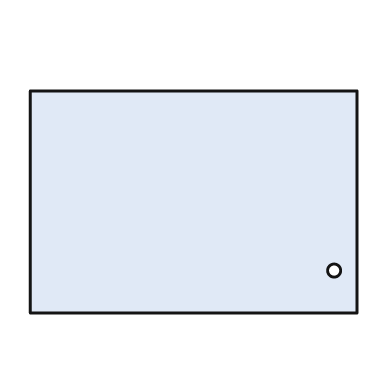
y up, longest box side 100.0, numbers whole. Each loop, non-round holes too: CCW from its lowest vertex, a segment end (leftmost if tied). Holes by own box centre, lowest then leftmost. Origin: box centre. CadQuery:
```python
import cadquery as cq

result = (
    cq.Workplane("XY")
    .moveTo(-50.0, -34.0)
    .lineTo(50.0, -34.0)
    .lineTo(50.0, 34.0)
    .lineTo(-50.0, 34.0)
    .close()
    .moveTo(43.0, -21.0)
    .circle(2.0)
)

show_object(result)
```